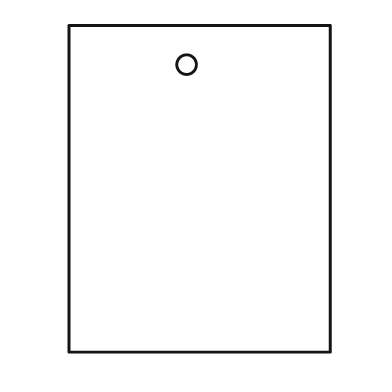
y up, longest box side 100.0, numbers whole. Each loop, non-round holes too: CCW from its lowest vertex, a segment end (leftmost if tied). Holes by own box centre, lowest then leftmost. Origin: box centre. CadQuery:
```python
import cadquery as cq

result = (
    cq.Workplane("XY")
    .moveTo(-40.0, -50.0)
    .lineTo(40.0, -50.0)
    .lineTo(40.0, 50.0)
    .lineTo(-40.0, 50.0)
    .close()
    .moveTo(-4.0, 38.0)
    .circle(3.0)
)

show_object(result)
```